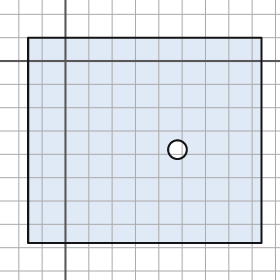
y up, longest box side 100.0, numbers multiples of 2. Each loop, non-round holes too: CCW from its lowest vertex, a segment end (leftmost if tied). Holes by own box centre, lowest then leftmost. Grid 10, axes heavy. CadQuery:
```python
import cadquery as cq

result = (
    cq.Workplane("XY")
    .moveTo(-16.0, -78.0)
    .lineTo(84.0, -78.0)
    .lineTo(84.0, 10.0)
    .lineTo(-16.0, 10.0)
    .close()
    .moveTo(48.0, -38.0)
    .circle(4.0)
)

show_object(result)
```